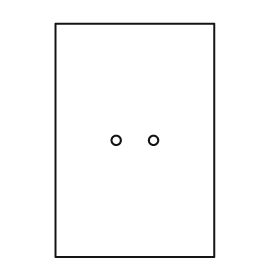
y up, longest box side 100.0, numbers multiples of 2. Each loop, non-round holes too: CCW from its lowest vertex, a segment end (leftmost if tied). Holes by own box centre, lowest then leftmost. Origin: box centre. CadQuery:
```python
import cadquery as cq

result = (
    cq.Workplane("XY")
    .moveTo(-34.0, -50.0)
    .lineTo(34.0, -50.0)
    .lineTo(34.0, 50.0)
    .lineTo(-34.0, 50.0)
    .close()
    .moveTo(-8.0, 0.0)
    .circle(2.0)
    .moveTo(8.0, 0.0)
    .circle(2.0)
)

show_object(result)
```